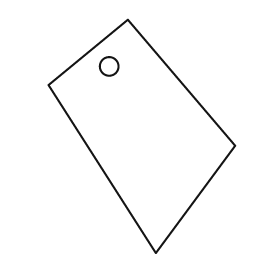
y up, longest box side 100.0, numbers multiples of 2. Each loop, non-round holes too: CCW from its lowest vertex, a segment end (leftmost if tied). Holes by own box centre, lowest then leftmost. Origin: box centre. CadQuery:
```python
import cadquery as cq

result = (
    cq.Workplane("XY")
    .moveTo(6.0, -50.0)
    .lineTo(40.0, -4.0)
    .lineTo(-6.0, 50.0)
    .lineTo(-40.0, 22.0)
    .close()
    .moveTo(-14.0, 30.0)
    .circle(4.0)
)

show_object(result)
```